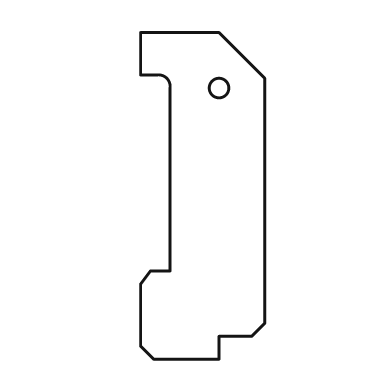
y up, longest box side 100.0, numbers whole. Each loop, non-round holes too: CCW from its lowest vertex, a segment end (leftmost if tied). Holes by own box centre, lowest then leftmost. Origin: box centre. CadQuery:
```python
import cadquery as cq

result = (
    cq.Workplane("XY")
    .moveTo(-15.0, -50.0)
    .lineTo(5.0, -50.0)
    .lineTo(5.0, -43.0)
    .lineTo(15.0, -43.0)
    .lineTo(19.0, -39.0)
    .lineTo(19.0, 36.0)
    .lineTo(5.0, 50.0)
    .lineTo(-19.0, 50.0)
    .lineTo(-19.0, 37.0)
    .lineTo(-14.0, 37.0)
    .threePointArc((-11.0, 36.0), (-10.0, 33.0))
    .lineTo(-10.0, -23.0)
    .lineTo(-16.0, -23.0)
    .lineTo(-19.0, -27.0)
    .lineTo(-19.0, -46.0)
    .close()
    .moveTo(5.0, 33.0)
    .circle(3.0)
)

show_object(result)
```